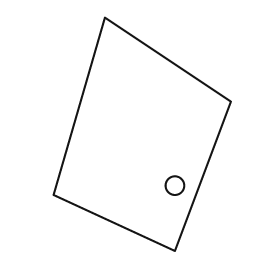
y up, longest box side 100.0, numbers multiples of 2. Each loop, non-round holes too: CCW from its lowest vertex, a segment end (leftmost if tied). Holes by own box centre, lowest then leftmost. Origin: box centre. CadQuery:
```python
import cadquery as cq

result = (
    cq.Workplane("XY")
    .moveTo(14.0, -50.0)
    .lineTo(38.0, 14.0)
    .lineTo(-16.0, 50.0)
    .lineTo(-38.0, -26.0)
    .close()
    .moveTo(14.0, -22.0)
    .circle(4.0)
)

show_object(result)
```